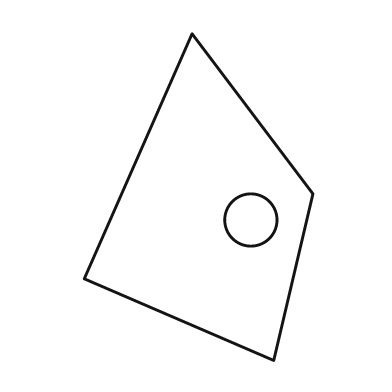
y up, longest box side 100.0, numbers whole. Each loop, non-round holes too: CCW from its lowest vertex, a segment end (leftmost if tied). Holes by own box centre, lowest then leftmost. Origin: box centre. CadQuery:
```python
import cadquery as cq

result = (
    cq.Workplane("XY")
    .moveTo(23.0, -50.0)
    .lineTo(35.0, 1.0)
    .lineTo(-2.0, 50.0)
    .lineTo(-35.0, -25.0)
    .close()
    .moveTo(16.0, -7.0)
    .circle(8.0)
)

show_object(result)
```